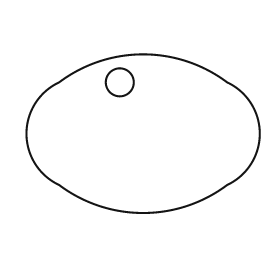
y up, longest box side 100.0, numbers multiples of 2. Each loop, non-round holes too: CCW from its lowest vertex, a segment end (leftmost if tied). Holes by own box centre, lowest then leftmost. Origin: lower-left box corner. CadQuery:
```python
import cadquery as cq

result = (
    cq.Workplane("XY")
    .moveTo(14.0, 12.0)
    .threePointArc((50.0, 0.0), (86.0, 12.0))
    .threePointArc((100.0, 34.0), (86.0, 56.0))
    .threePointArc((50.0, 68.0), (14.0, 56.0))
    .threePointArc((0.0, 34.0), (14.0, 12.0))
    .close()
    .moveTo(40.0, 56.0)
    .circle(6.0)
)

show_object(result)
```